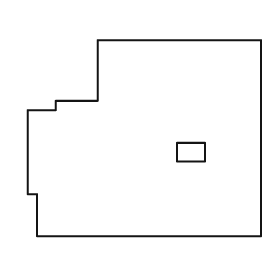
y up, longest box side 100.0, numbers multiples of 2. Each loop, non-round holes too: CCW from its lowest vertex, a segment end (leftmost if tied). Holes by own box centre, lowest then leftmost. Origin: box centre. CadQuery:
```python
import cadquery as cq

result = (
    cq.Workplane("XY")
    .moveTo(-46.0, -42.0)
    .lineTo(50.0, -42.0)
    .lineTo(50.0, 42.0)
    .lineTo(-20.0, 42.0)
    .lineTo(-20.0, 16.0)
    .lineTo(-38.0, 16.0)
    .lineTo(-38.0, 12.0)
    .lineTo(-50.0, 12.0)
    .lineTo(-50.0, -24.0)
    .lineTo(-46.0, -24.0)
    .close()
    .moveTo(14.0, -10.0)
    .lineTo(26.0, -10.0)
    .lineTo(26.0, -2.0)
    .lineTo(14.0, -2.0)
    .close()
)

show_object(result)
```